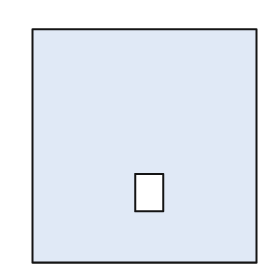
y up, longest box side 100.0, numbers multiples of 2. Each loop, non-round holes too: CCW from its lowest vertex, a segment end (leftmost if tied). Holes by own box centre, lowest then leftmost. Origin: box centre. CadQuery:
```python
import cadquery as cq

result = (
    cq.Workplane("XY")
    .moveTo(-48.0, -50.0)
    .lineTo(48.0, -50.0)
    .lineTo(48.0, 50.0)
    .lineTo(-48.0, 50.0)
    .close()
    .moveTo(-4.0, -28.0)
    .lineTo(8.0, -28.0)
    .lineTo(8.0, -12.0)
    .lineTo(-4.0, -12.0)
    .close()
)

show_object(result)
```